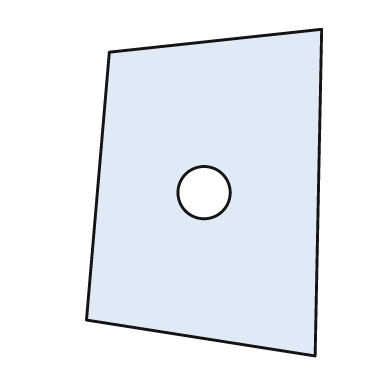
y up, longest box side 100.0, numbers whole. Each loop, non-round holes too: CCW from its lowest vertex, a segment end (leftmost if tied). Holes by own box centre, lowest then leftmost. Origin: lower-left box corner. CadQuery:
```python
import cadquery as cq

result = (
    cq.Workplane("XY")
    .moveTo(70.0, 0.0)
    .lineTo(72.0, 100.0)
    .lineTo(7.0, 93.0)
    .lineTo(0.0, 11.0)
    .close()
    .moveTo(36.0, 50.0)
    .circle(8.0)
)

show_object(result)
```